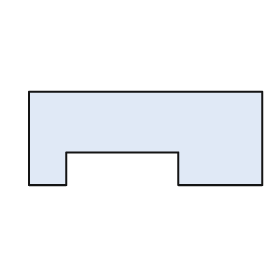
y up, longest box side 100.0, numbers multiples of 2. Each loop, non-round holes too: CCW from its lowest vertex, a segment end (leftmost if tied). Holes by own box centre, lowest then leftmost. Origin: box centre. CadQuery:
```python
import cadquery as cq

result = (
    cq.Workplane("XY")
    .moveTo(-50.0, -20.0)
    .lineTo(-34.0, -20.0)
    .lineTo(-34.0, -6.0)
    .lineTo(14.0, -6.0)
    .lineTo(14.0, -20.0)
    .lineTo(50.0, -20.0)
    .lineTo(50.0, 20.0)
    .lineTo(-50.0, 20.0)
    .close()
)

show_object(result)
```